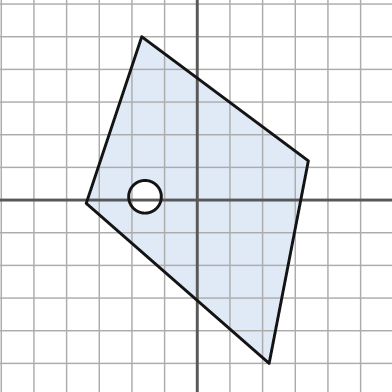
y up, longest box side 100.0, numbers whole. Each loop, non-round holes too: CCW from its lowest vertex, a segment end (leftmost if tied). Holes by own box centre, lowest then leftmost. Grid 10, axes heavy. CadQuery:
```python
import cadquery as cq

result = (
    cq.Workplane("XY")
    .moveTo(22.0, -50.0)
    .lineTo(34.0, 12.0)
    .lineTo(-17.0, 50.0)
    .lineTo(-34.0, -1.0)
    .close()
    .moveTo(-16.0, 1.0)
    .circle(5.0)
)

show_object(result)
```